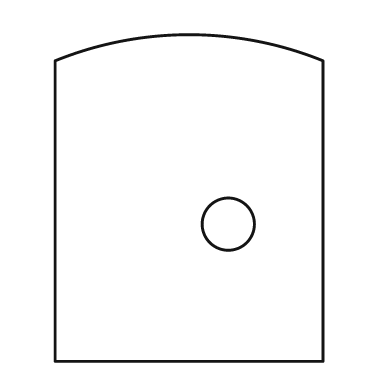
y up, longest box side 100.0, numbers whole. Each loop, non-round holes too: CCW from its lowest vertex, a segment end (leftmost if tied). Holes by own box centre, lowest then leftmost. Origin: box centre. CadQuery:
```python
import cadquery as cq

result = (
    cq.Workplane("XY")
    .moveTo(-41.0, -50.0)
    .lineTo(41.0, -50.0)
    .lineTo(41.0, 42.0)
    .threePointArc((0.0, 50.0), (-41.0, 42.0))
    .close()
    .moveTo(12.0, -8.0)
    .circle(8.0)
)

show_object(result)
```